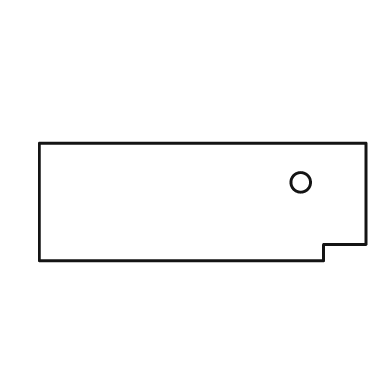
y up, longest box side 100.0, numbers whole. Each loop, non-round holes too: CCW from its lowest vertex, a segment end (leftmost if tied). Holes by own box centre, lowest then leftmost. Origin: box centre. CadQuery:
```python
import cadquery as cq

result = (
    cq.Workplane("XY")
    .moveTo(-50.0, -18.0)
    .lineTo(37.0, -18.0)
    .lineTo(37.0, -13.0)
    .lineTo(50.0, -13.0)
    .lineTo(50.0, 18.0)
    .lineTo(-50.0, 18.0)
    .close()
    .moveTo(30.0, 6.0)
    .circle(3.0)
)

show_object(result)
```